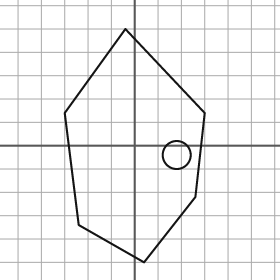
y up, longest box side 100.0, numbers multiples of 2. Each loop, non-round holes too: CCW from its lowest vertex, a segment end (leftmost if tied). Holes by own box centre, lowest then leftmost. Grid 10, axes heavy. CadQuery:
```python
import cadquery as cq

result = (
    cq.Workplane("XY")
    .moveTo(4.0, -50.0)
    .lineTo(26.0, -22.0)
    .lineTo(30.0, 14.0)
    .lineTo(-4.0, 50.0)
    .lineTo(-30.0, 14.0)
    .lineTo(-24.0, -34.0)
    .close()
    .moveTo(18.0, -4.0)
    .circle(6.0)
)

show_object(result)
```